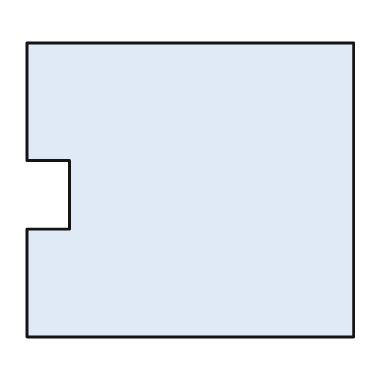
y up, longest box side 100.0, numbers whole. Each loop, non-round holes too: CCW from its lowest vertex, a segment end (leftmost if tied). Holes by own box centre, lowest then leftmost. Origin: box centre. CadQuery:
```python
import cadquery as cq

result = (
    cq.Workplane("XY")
    .moveTo(-50.0, -45.0)
    .lineTo(50.0, -45.0)
    .lineTo(50.0, 45.0)
    .lineTo(-50.0, 45.0)
    .lineTo(-50.0, 9.0)
    .lineTo(-37.0, 9.0)
    .lineTo(-37.0, -12.0)
    .lineTo(-50.0, -12.0)
    .close()
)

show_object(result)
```